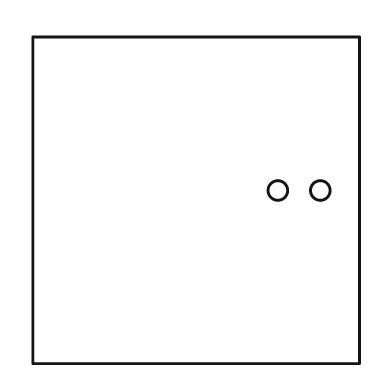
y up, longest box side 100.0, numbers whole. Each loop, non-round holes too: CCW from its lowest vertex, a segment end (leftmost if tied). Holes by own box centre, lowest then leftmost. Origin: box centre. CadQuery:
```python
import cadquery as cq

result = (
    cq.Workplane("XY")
    .moveTo(-50.0, -50.0)
    .lineTo(50.0, -50.0)
    .lineTo(50.0, 50.0)
    .lineTo(-50.0, 50.0)
    .close()
    .moveTo(25.0, 3.0)
    .circle(3.0)
    .moveTo(38.0, 3.0)
    .circle(3.0)
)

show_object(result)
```